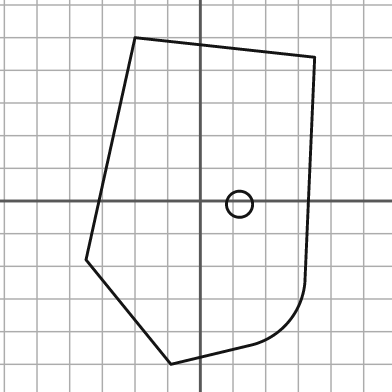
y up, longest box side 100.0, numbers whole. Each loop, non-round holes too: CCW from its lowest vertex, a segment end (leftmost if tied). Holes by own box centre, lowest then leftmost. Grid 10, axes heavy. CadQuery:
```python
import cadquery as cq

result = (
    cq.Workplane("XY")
    .moveTo(-9.0, -50.0)
    .lineTo(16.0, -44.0)
    .threePointArc((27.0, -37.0), (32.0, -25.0))
    .lineTo(35.0, 44.0)
    .lineTo(-20.0, 50.0)
    .lineTo(-35.0, -18.0)
    .close()
    .moveTo(12.0, -1.0)
    .circle(4.0)
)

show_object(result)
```